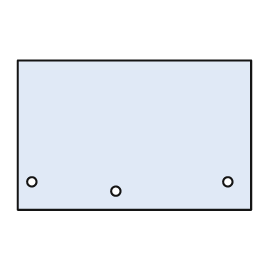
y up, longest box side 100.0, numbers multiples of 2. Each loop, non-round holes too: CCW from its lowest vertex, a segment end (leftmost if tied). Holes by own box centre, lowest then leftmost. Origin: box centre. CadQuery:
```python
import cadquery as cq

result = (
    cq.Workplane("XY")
    .moveTo(-50.0, -32.0)
    .lineTo(50.0, -32.0)
    .lineTo(50.0, 32.0)
    .lineTo(-50.0, 32.0)
    .close()
    .moveTo(-8.0, -24.0)
    .circle(2.0)
    .moveTo(-44.0, -20.0)
    .circle(2.0)
    .moveTo(40.0, -20.0)
    .circle(2.0)
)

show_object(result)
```